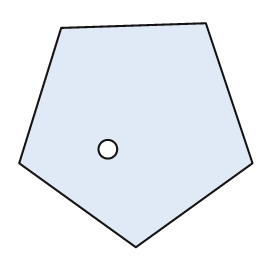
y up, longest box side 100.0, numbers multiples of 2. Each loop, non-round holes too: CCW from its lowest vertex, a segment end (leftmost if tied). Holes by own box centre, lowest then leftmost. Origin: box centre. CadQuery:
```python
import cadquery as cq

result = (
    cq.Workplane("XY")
    .moveTo(0.0, -48.0)
    .lineTo(50.0, -12.0)
    .lineTo(30.0, 48.0)
    .lineTo(-32.0, 46.0)
    .lineTo(-50.0, -12.0)
    .close()
    .moveTo(-12.0, -6.0)
    .circle(4.0)
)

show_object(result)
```